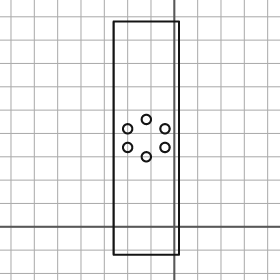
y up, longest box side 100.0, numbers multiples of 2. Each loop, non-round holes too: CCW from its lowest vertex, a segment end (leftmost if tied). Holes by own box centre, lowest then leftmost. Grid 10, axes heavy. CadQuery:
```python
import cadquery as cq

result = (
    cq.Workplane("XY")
    .moveTo(-26.0, -12.0)
    .lineTo(2.0, -12.0)
    .lineTo(2.0, 88.0)
    .lineTo(-26.0, 88.0)
    .close()
    .moveTo(-12.0, 30.0)
    .circle(2.0)
    .moveTo(-20.0, 34.0)
    .circle(2.0)
    .moveTo(-4.0, 34.0)
    .circle(2.0)
    .moveTo(-20.0, 42.0)
    .circle(2.0)
    .moveTo(-4.0, 42.0)
    .circle(2.0)
    .moveTo(-12.0, 46.0)
    .circle(2.0)
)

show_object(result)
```